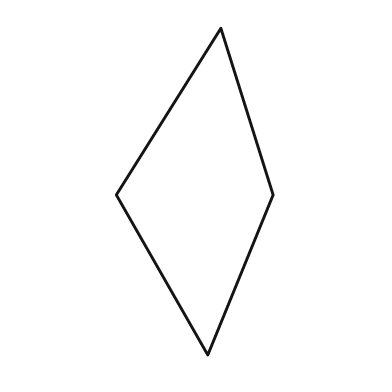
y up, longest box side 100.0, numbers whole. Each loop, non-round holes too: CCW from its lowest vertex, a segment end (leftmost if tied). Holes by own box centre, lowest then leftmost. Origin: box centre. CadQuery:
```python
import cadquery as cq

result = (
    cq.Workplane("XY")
    .moveTo(4.0, -50.0)
    .lineTo(24.0, -1.0)
    .lineTo(8.0, 50.0)
    .lineTo(-24.0, -1.0)
    .close()
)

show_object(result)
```